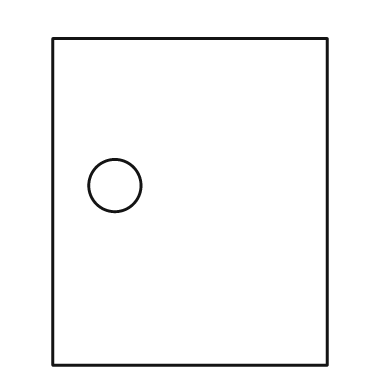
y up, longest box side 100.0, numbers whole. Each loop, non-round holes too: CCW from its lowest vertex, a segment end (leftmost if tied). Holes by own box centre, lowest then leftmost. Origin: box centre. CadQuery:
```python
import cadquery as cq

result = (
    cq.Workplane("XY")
    .moveTo(-42.0, -50.0)
    .lineTo(42.0, -50.0)
    .lineTo(42.0, 50.0)
    .lineTo(-42.0, 50.0)
    .close()
    .moveTo(-23.0, 5.0)
    .circle(8.0)
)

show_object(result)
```